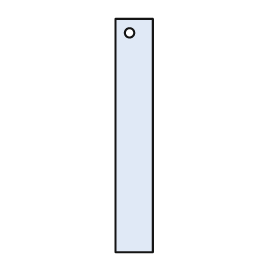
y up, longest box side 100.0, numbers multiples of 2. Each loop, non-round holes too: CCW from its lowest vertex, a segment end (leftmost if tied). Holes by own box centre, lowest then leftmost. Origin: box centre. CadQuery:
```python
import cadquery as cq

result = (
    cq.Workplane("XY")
    .moveTo(-8.0, -50.0)
    .lineTo(8.0, -50.0)
    .lineTo(8.0, 50.0)
    .lineTo(-8.0, 50.0)
    .close()
    .moveTo(-2.0, 44.0)
    .circle(2.0)
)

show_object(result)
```